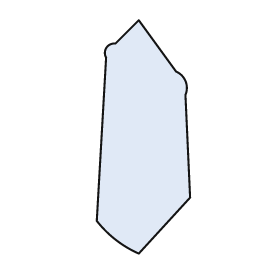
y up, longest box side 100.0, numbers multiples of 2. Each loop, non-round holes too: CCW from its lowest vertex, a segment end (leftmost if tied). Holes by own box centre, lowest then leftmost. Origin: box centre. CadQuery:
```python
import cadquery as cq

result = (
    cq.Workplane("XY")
    .moveTo(-2.0, -50.0)
    .lineTo(20.0, -26.0)
    .lineTo(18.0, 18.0)
    .threePointArc((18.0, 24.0), (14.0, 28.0))
    .lineTo(-2.0, 50.0)
    .lineTo(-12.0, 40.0)
    .threePointArc((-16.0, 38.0), (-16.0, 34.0))
    .lineTo(-20.0, -36.0)
    .threePointArc((-12.0, -44.0), (-2.0, -50.0))
    .close()
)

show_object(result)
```